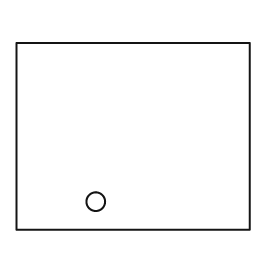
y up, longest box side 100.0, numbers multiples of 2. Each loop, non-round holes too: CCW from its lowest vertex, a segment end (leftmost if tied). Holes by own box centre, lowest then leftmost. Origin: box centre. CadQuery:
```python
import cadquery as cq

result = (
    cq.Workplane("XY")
    .moveTo(-50.0, -40.0)
    .lineTo(50.0, -40.0)
    .lineTo(50.0, 40.0)
    .lineTo(-50.0, 40.0)
    .close()
    .moveTo(-16.0, -28.0)
    .circle(4.0)
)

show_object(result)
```